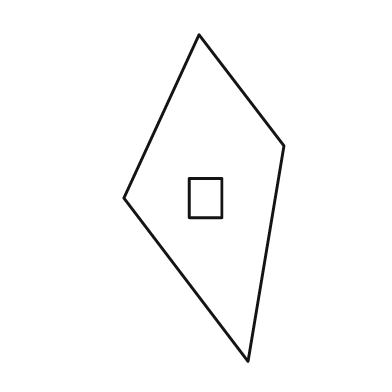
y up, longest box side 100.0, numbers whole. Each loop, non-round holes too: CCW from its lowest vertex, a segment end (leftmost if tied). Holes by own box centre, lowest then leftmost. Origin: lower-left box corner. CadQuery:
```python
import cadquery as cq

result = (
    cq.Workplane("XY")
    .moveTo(38.0, 0.0)
    .lineTo(49.0, 66.0)
    .lineTo(23.0, 100.0)
    .lineTo(0.0, 50.0)
    .close()
    .moveTo(20.0, 44.0)
    .lineTo(30.0, 44.0)
    .lineTo(30.0, 56.0)
    .lineTo(20.0, 56.0)
    .close()
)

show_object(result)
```